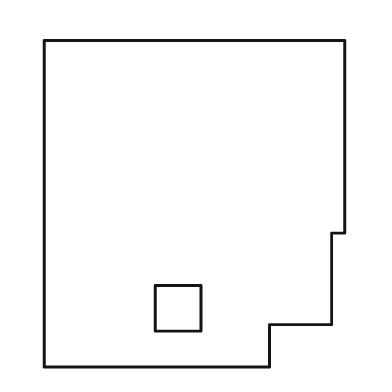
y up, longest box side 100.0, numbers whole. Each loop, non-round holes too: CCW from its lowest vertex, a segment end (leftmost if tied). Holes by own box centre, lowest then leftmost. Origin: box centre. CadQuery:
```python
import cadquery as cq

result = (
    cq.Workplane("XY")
    .moveTo(-46.0, -50.0)
    .lineTo(23.0, -50.0)
    .lineTo(23.0, -37.0)
    .lineTo(42.0, -37.0)
    .lineTo(42.0, -9.0)
    .lineTo(46.0, -9.0)
    .lineTo(46.0, 50.0)
    .lineTo(-46.0, 50.0)
    .close()
    .moveTo(-12.0, -39.0)
    .lineTo(2.0, -39.0)
    .lineTo(2.0, -25.0)
    .lineTo(-12.0, -25.0)
    .close()
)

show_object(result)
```